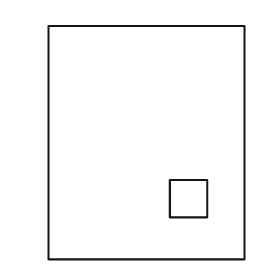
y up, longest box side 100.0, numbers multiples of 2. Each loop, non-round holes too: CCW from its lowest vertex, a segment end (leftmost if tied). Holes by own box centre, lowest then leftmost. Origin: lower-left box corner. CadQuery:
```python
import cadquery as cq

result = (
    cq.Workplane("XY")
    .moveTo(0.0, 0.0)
    .lineTo(84.0, 0.0)
    .lineTo(84.0, 100.0)
    .lineTo(0.0, 100.0)
    .close()
    .moveTo(52.0, 18.0)
    .lineTo(68.0, 18.0)
    .lineTo(68.0, 34.0)
    .lineTo(52.0, 34.0)
    .close()
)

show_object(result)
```